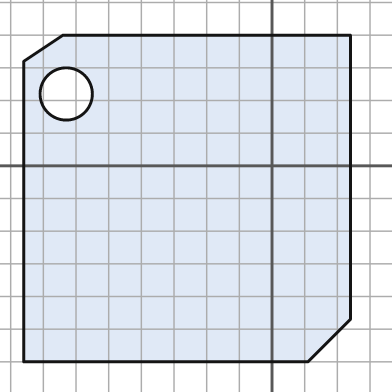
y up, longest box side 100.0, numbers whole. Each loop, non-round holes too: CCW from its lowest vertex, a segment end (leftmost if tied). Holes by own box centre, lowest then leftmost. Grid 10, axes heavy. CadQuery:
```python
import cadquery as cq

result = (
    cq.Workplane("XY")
    .moveTo(-76.0, -60.0)
    .lineTo(11.0, -60.0)
    .lineTo(24.0, -47.0)
    .lineTo(24.0, 40.0)
    .lineTo(-64.0, 40.0)
    .lineTo(-76.0, 32.0)
    .close()
    .moveTo(-63.0, 22.0)
    .circle(8.0)
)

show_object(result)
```